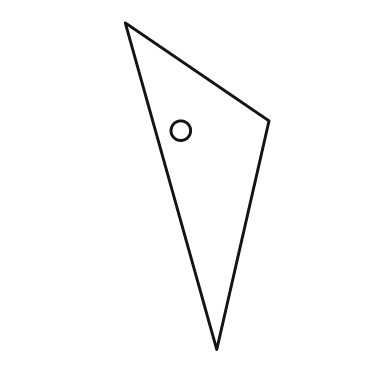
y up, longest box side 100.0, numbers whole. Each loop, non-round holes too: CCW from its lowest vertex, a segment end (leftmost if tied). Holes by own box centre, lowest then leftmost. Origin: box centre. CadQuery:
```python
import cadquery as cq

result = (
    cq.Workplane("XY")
    .moveTo(6.0, -50.0)
    .lineTo(22.0, 20.0)
    .lineTo(-22.0, 50.0)
    .close()
    .moveTo(-5.0, 17.0)
    .circle(3.0)
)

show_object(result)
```